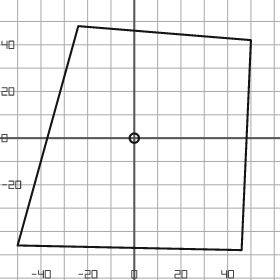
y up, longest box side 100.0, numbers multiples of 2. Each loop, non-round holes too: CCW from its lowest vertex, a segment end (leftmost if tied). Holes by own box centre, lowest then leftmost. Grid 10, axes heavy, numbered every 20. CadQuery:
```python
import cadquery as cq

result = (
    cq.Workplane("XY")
    .moveTo(46.0, -48.0)
    .lineTo(50.0, 42.0)
    .lineTo(-24.0, 48.0)
    .lineTo(-50.0, -46.0)
    .close()
    .moveTo(0.0, 0.0)
    .circle(2.0)
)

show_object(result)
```